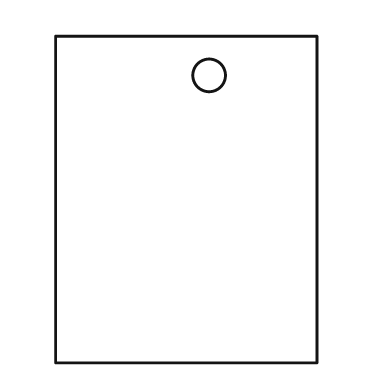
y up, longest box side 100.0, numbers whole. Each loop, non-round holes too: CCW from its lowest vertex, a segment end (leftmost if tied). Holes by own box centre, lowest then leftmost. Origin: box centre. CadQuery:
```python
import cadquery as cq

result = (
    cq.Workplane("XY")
    .moveTo(-40.0, -50.0)
    .lineTo(40.0, -50.0)
    .lineTo(40.0, 50.0)
    .lineTo(-40.0, 50.0)
    .close()
    .moveTo(7.0, 38.0)
    .circle(5.0)
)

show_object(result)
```